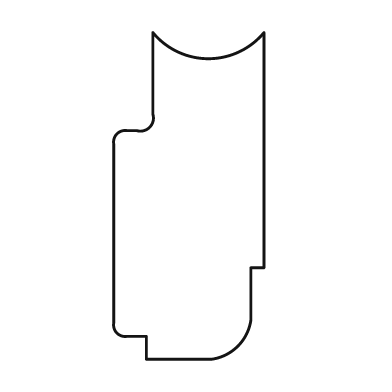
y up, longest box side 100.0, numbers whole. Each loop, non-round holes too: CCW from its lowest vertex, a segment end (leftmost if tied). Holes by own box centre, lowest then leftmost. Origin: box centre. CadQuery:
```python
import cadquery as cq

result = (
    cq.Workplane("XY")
    .moveTo(-13.0, -50.0)
    .lineTo(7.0, -50.0)
    .threePointArc((15.0, -46.0), (19.0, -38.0))
    .lineTo(19.0, -22.0)
    .lineTo(23.0, -22.0)
    .lineTo(23.0, 50.0)
    .threePointArc((6.0, 42.0), (-11.0, 50.0))
    .lineTo(-11.0, 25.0)
    .threePointArc((-12.0, 21.0), (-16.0, 20.0))
    .lineTo(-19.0, 20.0)
    .threePointArc((-22.0, 19.0), (-23.0, 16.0))
    .lineTo(-23.0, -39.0)
    .threePointArc((-22.0, -42.0), (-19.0, -43.0))
    .lineTo(-13.0, -43.0)
    .close()
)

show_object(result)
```